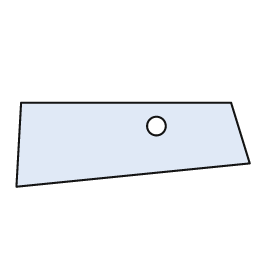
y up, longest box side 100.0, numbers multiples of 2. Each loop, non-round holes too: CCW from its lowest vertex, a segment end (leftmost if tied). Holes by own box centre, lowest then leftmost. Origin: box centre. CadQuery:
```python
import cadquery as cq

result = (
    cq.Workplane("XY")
    .moveTo(-50.0, -18.0)
    .lineTo(50.0, -8.0)
    .lineTo(42.0, 18.0)
    .lineTo(-48.0, 18.0)
    .close()
    .moveTo(10.0, 8.0)
    .circle(4.0)
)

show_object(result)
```